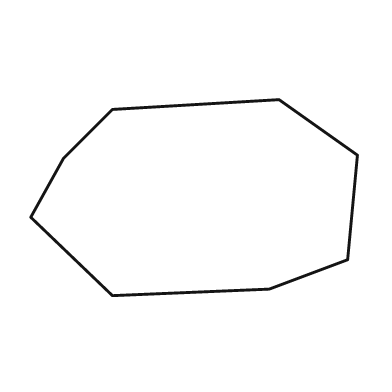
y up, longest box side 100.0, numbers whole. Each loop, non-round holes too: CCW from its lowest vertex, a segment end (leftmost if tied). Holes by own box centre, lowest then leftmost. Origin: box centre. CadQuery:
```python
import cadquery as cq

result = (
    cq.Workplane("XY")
    .moveTo(-25.0, -30.0)
    .lineTo(23.0, -28.0)
    .lineTo(47.0, -19.0)
    .lineTo(50.0, 13.0)
    .lineTo(26.0, 30.0)
    .lineTo(-25.0, 27.0)
    .lineTo(-40.0, 12.0)
    .lineTo(-50.0, -6.0)
    .close()
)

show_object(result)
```